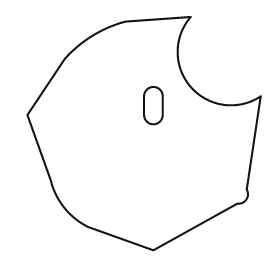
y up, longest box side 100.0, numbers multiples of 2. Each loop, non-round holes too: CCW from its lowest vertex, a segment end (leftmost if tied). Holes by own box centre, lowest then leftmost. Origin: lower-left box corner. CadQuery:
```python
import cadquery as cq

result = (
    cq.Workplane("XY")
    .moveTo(54.0, 0.0)
    .lineTo(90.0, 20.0)
    .threePointArc((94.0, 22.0), (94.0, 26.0))
    .lineTo(100.0, 66.0)
    .threePointArc((70.0, 70.0), (70.0, 100.0))
    .lineTo(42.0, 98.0)
    .threePointArc((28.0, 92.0), (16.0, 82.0))
    .lineTo(0.0, 58.0)
    .lineTo(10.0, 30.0)
    .threePointArc((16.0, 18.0), (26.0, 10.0))
    .close()
    .moveTo(50.0, 58.0)
    .threePointArc((54.0, 54.0), (58.0, 58.0))
    .lineTo(58.0, 66.0)
    .threePointArc((54.0, 70.0), (50.0, 66.0))
    .close()
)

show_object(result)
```